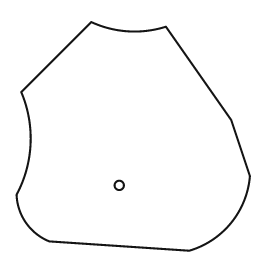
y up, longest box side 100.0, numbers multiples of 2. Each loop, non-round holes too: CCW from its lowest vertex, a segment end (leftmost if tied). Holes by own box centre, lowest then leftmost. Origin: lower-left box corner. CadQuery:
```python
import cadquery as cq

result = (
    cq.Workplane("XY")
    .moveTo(74.0, 0.0)
    .threePointArc((92.0, 12.0), (100.0, 32.0))
    .lineTo(92.0, 56.0)
    .lineTo(64.0, 96.0)
    .threePointArc((48.0, 94.0), (32.0, 98.0))
    .lineTo(2.0, 68.0)
    .threePointArc((6.0, 46.0), (0.0, 24.0))
    .threePointArc((4.0, 12.0), (14.0, 4.0))
    .close()
    .moveTo(44.0, 28.0)
    .circle(2.0)
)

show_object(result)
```